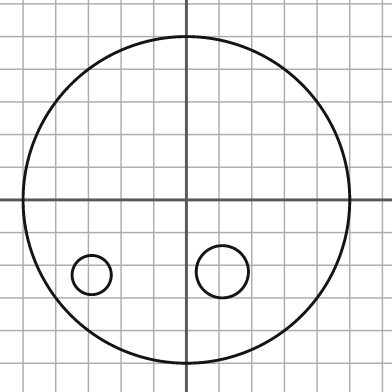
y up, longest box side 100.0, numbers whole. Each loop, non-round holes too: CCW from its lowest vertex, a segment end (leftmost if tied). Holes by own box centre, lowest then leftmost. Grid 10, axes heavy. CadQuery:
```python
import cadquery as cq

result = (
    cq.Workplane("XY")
    .moveTo(0.0, 0.0)
    .circle(50.0)
    .moveTo(-29.0, -23.0)
    .circle(6.0)
    .moveTo(11.0, -22.0)
    .circle(8.0)
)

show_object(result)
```